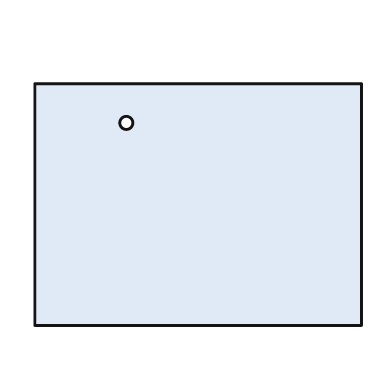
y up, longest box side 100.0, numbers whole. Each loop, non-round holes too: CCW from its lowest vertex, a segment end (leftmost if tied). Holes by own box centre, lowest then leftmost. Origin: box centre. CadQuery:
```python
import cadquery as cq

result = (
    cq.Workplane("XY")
    .moveTo(-50.0, -37.0)
    .lineTo(50.0, -37.0)
    .lineTo(50.0, 37.0)
    .lineTo(-50.0, 37.0)
    .close()
    .moveTo(-22.0, 25.0)
    .circle(2.0)
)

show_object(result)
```